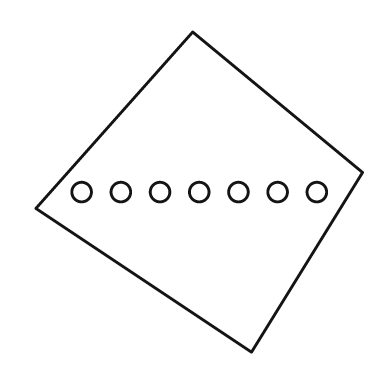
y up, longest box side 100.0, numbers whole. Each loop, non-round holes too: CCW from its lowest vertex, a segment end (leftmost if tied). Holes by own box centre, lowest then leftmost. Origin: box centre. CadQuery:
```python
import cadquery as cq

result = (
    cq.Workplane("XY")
    .moveTo(16.0, -49.0)
    .lineTo(50.0, 6.0)
    .lineTo(-2.0, 49.0)
    .lineTo(-50.0, -5.0)
    .close()
    .moveTo(-36.0, 0.0)
    .circle(3.0)
    .moveTo(-24.0, 0.0)
    .circle(3.0)
    .moveTo(-12.0, 0.0)
    .circle(3.0)
    .moveTo(0.0, 0.0)
    .circle(3.0)
    .moveTo(12.0, 0.0)
    .circle(3.0)
    .moveTo(24.0, 0.0)
    .circle(3.0)
    .moveTo(36.0, 0.0)
    .circle(3.0)
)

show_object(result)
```